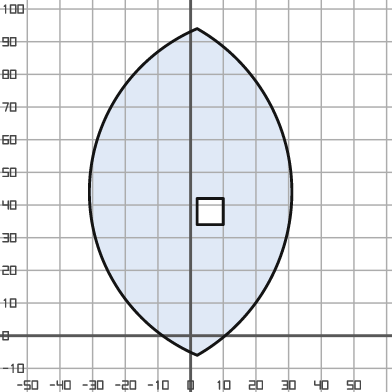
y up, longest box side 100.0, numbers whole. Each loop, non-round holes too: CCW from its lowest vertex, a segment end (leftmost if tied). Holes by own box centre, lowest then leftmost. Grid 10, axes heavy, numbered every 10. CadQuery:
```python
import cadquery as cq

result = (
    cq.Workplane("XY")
    .moveTo(2.0, -6.0)
    .threePointArc((31.0, 44.0), (2.0, 94.0))
    .threePointArc((-31.0, 44.0), (2.0, -6.0))
    .close()
    .moveTo(2.0, 34.0)
    .lineTo(10.0, 34.0)
    .lineTo(10.0, 42.0)
    .lineTo(2.0, 42.0)
    .close()
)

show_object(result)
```